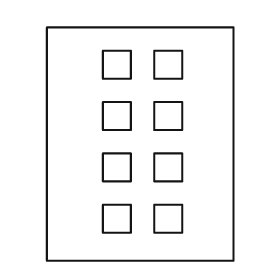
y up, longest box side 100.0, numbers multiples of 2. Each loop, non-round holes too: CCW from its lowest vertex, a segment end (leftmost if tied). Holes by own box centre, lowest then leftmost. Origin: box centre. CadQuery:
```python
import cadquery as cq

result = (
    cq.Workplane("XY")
    .moveTo(-40.0, -50.0)
    .lineTo(40.0, -50.0)
    .lineTo(40.0, 50.0)
    .lineTo(-40.0, 50.0)
    .close()
    .moveTo(-16.0, -38.0)
    .lineTo(-4.0, -38.0)
    .lineTo(-4.0, -26.0)
    .lineTo(-16.0, -26.0)
    .close()
    .moveTo(6.0, -38.0)
    .lineTo(18.0, -38.0)
    .lineTo(18.0, -26.0)
    .lineTo(6.0, -26.0)
    .close()
    .moveTo(-16.0, -16.0)
    .lineTo(-4.0, -16.0)
    .lineTo(-4.0, -4.0)
    .lineTo(-16.0, -4.0)
    .close()
    .moveTo(6.0, -16.0)
    .lineTo(18.0, -16.0)
    .lineTo(18.0, -4.0)
    .lineTo(6.0, -4.0)
    .close()
    .moveTo(-16.0, 6.0)
    .lineTo(-4.0, 6.0)
    .lineTo(-4.0, 18.0)
    .lineTo(-16.0, 18.0)
    .close()
    .moveTo(6.0, 6.0)
    .lineTo(18.0, 6.0)
    .lineTo(18.0, 18.0)
    .lineTo(6.0, 18.0)
    .close()
    .moveTo(-16.0, 28.0)
    .lineTo(-4.0, 28.0)
    .lineTo(-4.0, 40.0)
    .lineTo(-16.0, 40.0)
    .close()
    .moveTo(6.0, 28.0)
    .lineTo(18.0, 28.0)
    .lineTo(18.0, 40.0)
    .lineTo(6.0, 40.0)
    .close()
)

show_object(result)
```